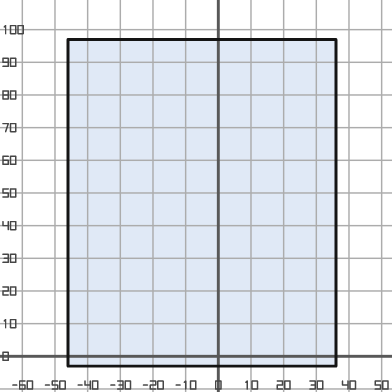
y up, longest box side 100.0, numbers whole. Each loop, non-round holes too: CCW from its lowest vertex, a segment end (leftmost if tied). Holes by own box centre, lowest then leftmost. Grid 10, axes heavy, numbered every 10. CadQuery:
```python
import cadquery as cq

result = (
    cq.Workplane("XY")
    .moveTo(-46.0, -3.0)
    .lineTo(36.0, -3.0)
    .lineTo(36.0, 97.0)
    .lineTo(-46.0, 97.0)
    .close()
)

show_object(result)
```